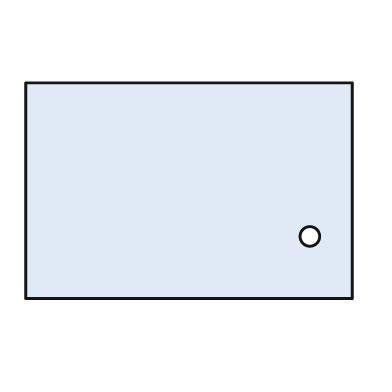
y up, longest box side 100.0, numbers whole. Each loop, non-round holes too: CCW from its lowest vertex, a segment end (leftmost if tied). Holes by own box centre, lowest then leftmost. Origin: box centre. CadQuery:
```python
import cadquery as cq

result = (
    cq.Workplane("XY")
    .moveTo(-50.0, -33.0)
    .lineTo(50.0, -33.0)
    .lineTo(50.0, 33.0)
    .lineTo(-50.0, 33.0)
    .close()
    .moveTo(37.0, -14.0)
    .circle(3.0)
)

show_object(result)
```